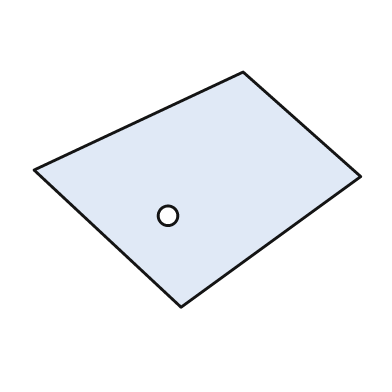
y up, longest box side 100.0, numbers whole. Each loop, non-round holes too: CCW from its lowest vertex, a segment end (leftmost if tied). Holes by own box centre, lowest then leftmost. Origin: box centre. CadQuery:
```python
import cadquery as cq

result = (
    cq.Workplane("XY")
    .moveTo(-5.0, -36.0)
    .lineTo(50.0, 4.0)
    .lineTo(14.0, 36.0)
    .lineTo(-50.0, 6.0)
    .close()
    .moveTo(-9.0, -8.0)
    .circle(3.0)
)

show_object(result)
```